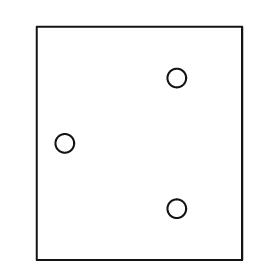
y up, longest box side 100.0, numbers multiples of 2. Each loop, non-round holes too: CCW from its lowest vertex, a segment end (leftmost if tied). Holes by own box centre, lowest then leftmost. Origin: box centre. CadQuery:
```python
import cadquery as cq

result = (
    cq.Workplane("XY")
    .moveTo(-44.0, -50.0)
    .lineTo(44.0, -50.0)
    .lineTo(44.0, 50.0)
    .lineTo(-44.0, 50.0)
    .close()
    .moveTo(16.0, -28.0)
    .circle(4.0)
    .moveTo(-32.0, 0.0)
    .circle(4.0)
    .moveTo(16.0, 28.0)
    .circle(4.0)
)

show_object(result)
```